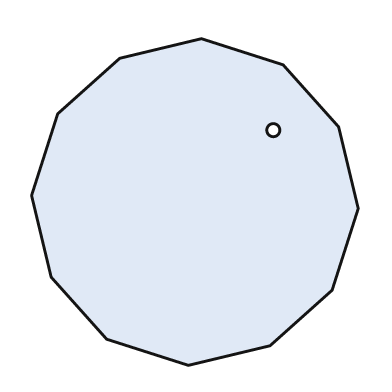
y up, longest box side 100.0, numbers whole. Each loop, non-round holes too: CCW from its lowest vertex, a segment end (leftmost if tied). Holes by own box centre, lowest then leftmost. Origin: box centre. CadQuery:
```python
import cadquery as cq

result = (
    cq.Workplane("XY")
    .moveTo(-2.0, -50.0)
    .lineTo(23.0, -44.0)
    .lineTo(42.0, -27.0)
    .lineTo(50.0, -2.0)
    .lineTo(44.0, 23.0)
    .lineTo(27.0, 42.0)
    .lineTo(2.0, 50.0)
    .lineTo(-23.0, 44.0)
    .lineTo(-42.0, 27.0)
    .lineTo(-50.0, 2.0)
    .lineTo(-44.0, -23.0)
    .lineTo(-27.0, -42.0)
    .close()
    .moveTo(24.0, 22.0)
    .circle(2.0)
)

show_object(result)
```